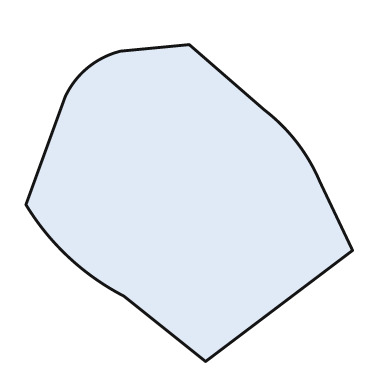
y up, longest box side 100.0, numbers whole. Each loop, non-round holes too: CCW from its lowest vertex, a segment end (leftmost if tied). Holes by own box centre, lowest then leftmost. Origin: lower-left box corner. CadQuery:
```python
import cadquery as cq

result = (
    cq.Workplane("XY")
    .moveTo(55.0, 0.0)
    .lineTo(100.0, 34.0)
    .lineTo(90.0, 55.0)
    .threePointArc((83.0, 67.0), (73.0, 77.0))
    .lineTo(50.0, 97.0)
    .lineTo(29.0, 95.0)
    .threePointArc((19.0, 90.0), (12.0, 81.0))
    .lineTo(0.0, 48.0)
    .threePointArc((13.0, 32.0), (30.0, 20.0))
    .close()
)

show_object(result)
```